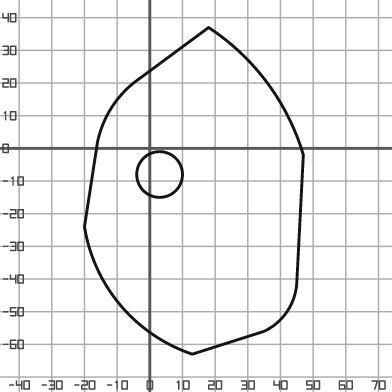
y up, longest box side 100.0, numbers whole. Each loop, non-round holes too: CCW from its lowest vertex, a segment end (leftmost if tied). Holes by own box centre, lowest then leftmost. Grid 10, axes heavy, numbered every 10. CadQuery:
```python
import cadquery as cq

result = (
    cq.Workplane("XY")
    .moveTo(13.0, -63.0)
    .lineTo(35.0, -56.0)
    .threePointArc((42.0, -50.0), (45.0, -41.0))
    .lineTo(47.0, -2.0)
    .threePointArc((36.0, 20.0), (18.0, 37.0))
    .lineTo(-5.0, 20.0)
    .threePointArc((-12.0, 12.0), (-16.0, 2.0))
    .lineTo(-20.0, -24.0)
    .threePointArc((-9.0, -48.0), (13.0, -63.0))
    .close()
    .moveTo(3.0, -8.0)
    .circle(7.0)
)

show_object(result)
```